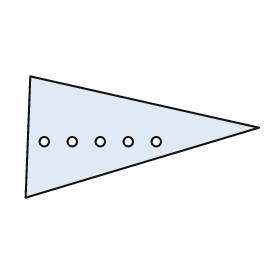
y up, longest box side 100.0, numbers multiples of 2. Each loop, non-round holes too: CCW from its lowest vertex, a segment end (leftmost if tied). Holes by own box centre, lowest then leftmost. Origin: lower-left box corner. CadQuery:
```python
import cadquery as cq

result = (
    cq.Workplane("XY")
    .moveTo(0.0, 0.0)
    .lineTo(100.0, 30.0)
    .lineTo(2.0, 52.0)
    .close()
    .moveTo(8.0, 24.0)
    .circle(2.0)
    .moveTo(20.0, 24.0)
    .circle(2.0)
    .moveTo(32.0, 24.0)
    .circle(2.0)
    .moveTo(44.0, 24.0)
    .circle(2.0)
    .moveTo(56.0, 24.0)
    .circle(2.0)
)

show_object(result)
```